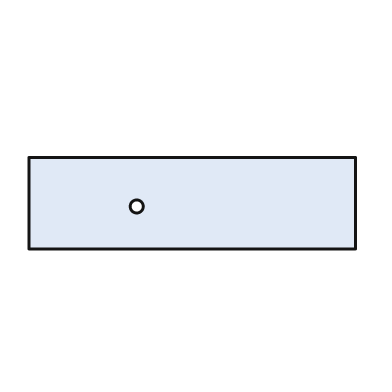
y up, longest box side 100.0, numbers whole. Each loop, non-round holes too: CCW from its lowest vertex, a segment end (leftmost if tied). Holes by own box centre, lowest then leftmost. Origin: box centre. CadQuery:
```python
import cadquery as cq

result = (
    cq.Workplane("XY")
    .moveTo(-50.0, -14.0)
    .lineTo(50.0, -14.0)
    .lineTo(50.0, 14.0)
    .lineTo(-50.0, 14.0)
    .close()
    .moveTo(-17.0, -1.0)
    .circle(2.0)
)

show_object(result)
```